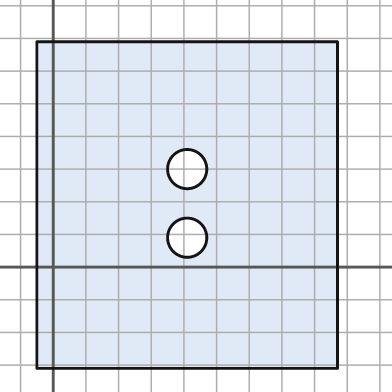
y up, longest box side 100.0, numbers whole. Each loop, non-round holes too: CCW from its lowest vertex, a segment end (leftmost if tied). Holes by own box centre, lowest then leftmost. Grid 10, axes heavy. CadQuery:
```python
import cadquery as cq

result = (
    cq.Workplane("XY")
    .moveTo(-5.0, -31.0)
    .lineTo(87.0, -31.0)
    .lineTo(87.0, 69.0)
    .lineTo(-5.0, 69.0)
    .close()
    .moveTo(41.0, 9.0)
    .circle(6.0)
    .moveTo(41.0, 30.0)
    .circle(6.0)
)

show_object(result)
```